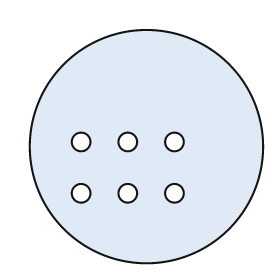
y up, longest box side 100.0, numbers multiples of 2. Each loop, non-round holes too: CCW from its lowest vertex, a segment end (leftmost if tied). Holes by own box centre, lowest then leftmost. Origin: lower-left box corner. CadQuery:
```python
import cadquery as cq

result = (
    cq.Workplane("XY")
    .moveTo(50.0, 50.0)
    .circle(50.0)
    .moveTo(22.0, 30.0)
    .circle(4.0)
    .moveTo(42.0, 30.0)
    .circle(4.0)
    .moveTo(62.0, 30.0)
    .circle(4.0)
    .moveTo(22.0, 52.0)
    .circle(4.0)
    .moveTo(42.0, 52.0)
    .circle(4.0)
    .moveTo(62.0, 52.0)
    .circle(4.0)
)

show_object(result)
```